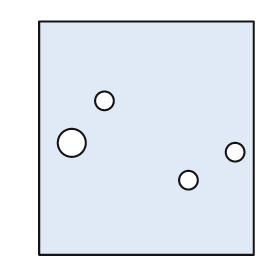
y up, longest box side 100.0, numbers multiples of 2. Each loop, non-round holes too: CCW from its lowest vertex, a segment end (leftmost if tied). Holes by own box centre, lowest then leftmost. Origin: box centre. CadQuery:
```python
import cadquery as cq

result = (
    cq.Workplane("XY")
    .moveTo(-46.0, -50.0)
    .lineTo(46.0, -50.0)
    .lineTo(46.0, 50.0)
    .lineTo(-46.0, 50.0)
    .close()
    .moveTo(18.0, -18.0)
    .circle(4.0)
    .moveTo(38.0, -6.0)
    .circle(4.0)
    .moveTo(-32.0, -2.0)
    .circle(6.0)
    .moveTo(-18.0, 16.0)
    .circle(4.0)
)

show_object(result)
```